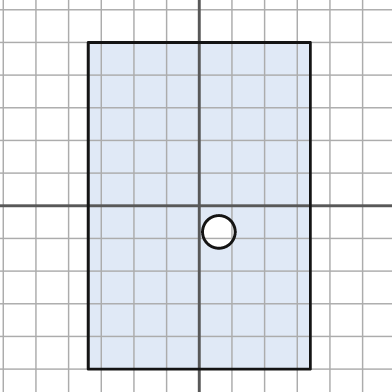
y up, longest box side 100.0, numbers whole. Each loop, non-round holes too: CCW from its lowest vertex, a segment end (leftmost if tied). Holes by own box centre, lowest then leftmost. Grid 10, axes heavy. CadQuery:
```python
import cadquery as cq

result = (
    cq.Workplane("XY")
    .moveTo(-34.0, -50.0)
    .lineTo(34.0, -50.0)
    .lineTo(34.0, 50.0)
    .lineTo(-34.0, 50.0)
    .close()
    .moveTo(6.0, -8.0)
    .circle(5.0)
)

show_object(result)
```